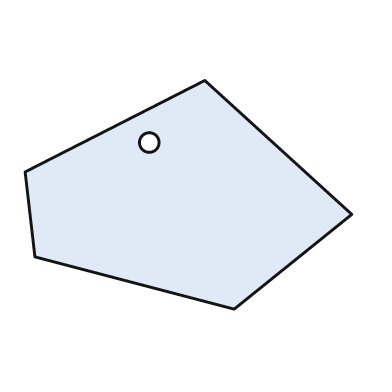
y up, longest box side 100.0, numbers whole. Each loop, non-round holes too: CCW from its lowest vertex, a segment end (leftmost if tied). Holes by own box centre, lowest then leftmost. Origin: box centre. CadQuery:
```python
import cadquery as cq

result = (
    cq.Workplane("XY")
    .moveTo(14.0, -35.0)
    .lineTo(50.0, -6.0)
    .lineTo(5.0, 35.0)
    .lineTo(-50.0, 7.0)
    .lineTo(-47.0, -19.0)
    .close()
    .moveTo(-12.0, 16.0)
    .circle(3.0)
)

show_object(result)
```